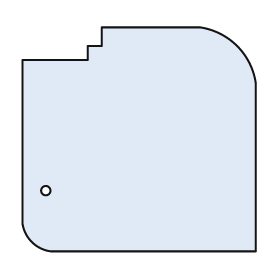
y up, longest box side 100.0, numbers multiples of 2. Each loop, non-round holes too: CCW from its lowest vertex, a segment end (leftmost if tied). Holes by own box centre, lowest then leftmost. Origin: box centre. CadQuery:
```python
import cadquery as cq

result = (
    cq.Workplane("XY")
    .moveTo(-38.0, -48.0)
    .lineTo(50.0, -48.0)
    .lineTo(50.0, 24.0)
    .threePointArc((42.0, 40.0), (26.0, 48.0))
    .lineTo(-16.0, 48.0)
    .lineTo(-16.0, 40.0)
    .lineTo(-22.0, 40.0)
    .lineTo(-22.0, 34.0)
    .lineTo(-50.0, 34.0)
    .lineTo(-50.0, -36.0)
    .threePointArc((-46.0, -44.0), (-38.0, -48.0))
    .close()
    .moveTo(-40.0, -22.0)
    .circle(2.0)
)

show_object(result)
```